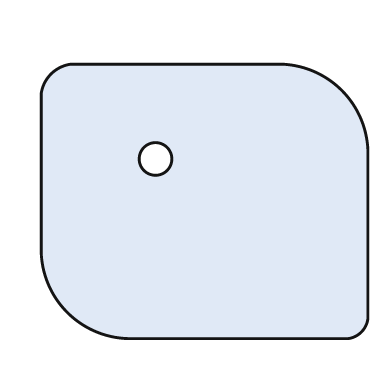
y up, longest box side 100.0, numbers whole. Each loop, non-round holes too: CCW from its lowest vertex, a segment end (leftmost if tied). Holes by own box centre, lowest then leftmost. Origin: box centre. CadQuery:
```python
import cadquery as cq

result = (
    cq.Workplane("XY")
    .moveTo(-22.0, -42.0)
    .lineTo(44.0, -42.0)
    .threePointArc((48.0, -40.0), (50.0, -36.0))
    .lineTo(50.0, 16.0)
    .threePointArc((42.0, 34.0), (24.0, 42.0))
    .lineTo(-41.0, 42.0)
    .threePointArc((-47.0, 39.0), (-50.0, 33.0))
    .lineTo(-50.0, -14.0)
    .threePointArc((-42.0, -34.0), (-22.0, -42.0))
    .close()
    .moveTo(-15.0, 13.0)
    .circle(5.0)
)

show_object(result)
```